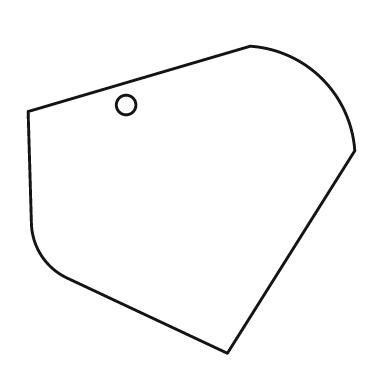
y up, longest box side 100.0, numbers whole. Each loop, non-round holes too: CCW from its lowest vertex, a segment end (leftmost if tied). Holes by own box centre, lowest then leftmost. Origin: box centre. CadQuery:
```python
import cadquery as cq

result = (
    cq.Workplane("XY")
    .moveTo(11.0, -47.0)
    .lineTo(50.0, 15.0)
    .threePointArc((40.0, 37.0), (18.0, 47.0))
    .lineTo(-50.0, 27.0)
    .lineTo(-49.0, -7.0)
    .threePointArc((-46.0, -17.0), (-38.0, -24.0))
    .close()
    .moveTo(-20.0, 29.0)
    .circle(3.0)
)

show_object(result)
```